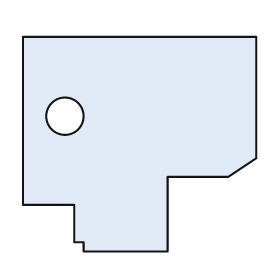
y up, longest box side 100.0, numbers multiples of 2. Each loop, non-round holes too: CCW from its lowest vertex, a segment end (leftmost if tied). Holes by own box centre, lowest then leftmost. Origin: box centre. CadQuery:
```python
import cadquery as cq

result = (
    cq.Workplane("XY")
    .moveTo(-24.0, -46.0)
    .lineTo(12.0, -46.0)
    .lineTo(12.0, -14.0)
    .lineTo(38.0, -14.0)
    .lineTo(50.0, -6.0)
    .lineTo(50.0, 46.0)
    .lineTo(-50.0, 46.0)
    .lineTo(-50.0, -26.0)
    .lineTo(-28.0, -26.0)
    .lineTo(-28.0, -42.0)
    .lineTo(-24.0, -42.0)
    .close()
    .moveTo(-32.0, 12.0)
    .circle(8.0)
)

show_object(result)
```